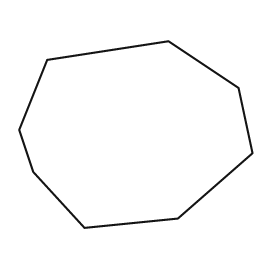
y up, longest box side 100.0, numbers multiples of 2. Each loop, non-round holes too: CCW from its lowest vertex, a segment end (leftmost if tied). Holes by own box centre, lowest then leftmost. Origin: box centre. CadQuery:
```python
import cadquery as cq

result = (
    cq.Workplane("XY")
    .moveTo(-22.0, -40.0)
    .lineTo(18.0, -36.0)
    .lineTo(50.0, -8.0)
    .lineTo(44.0, 20.0)
    .lineTo(14.0, 40.0)
    .lineTo(-38.0, 32.0)
    .lineTo(-50.0, 2.0)
    .lineTo(-44.0, -16.0)
    .close()
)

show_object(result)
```